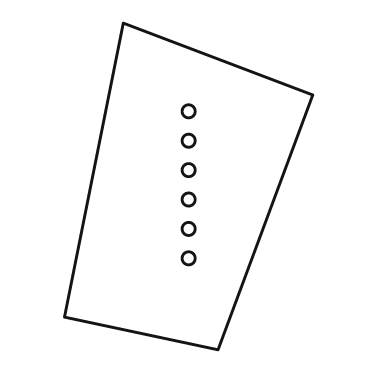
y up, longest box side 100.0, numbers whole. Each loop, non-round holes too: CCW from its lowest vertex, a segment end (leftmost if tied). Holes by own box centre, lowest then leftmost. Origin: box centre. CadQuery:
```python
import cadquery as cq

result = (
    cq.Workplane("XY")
    .moveTo(9.0, -50.0)
    .lineTo(38.0, 28.0)
    .lineTo(-20.0, 50.0)
    .lineTo(-38.0, -40.0)
    .close()
    .moveTo(0.0, -22.0)
    .circle(2.0)
    .moveTo(0.0, -13.0)
    .circle(2.0)
    .moveTo(0.0, -4.0)
    .circle(2.0)
    .moveTo(0.0, 5.0)
    .circle(2.0)
    .moveTo(0.0, 14.0)
    .circle(2.0)
    .moveTo(0.0, 23.0)
    .circle(2.0)
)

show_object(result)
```